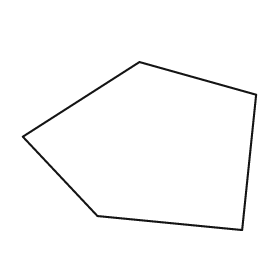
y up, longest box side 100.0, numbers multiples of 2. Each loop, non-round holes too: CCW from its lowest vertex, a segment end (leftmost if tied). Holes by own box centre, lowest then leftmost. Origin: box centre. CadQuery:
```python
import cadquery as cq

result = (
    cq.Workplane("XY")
    .moveTo(44.0, -36.0)
    .lineTo(50.0, 22.0)
    .lineTo(0.0, 36.0)
    .lineTo(-50.0, 4.0)
    .lineTo(-18.0, -30.0)
    .close()
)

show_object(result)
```